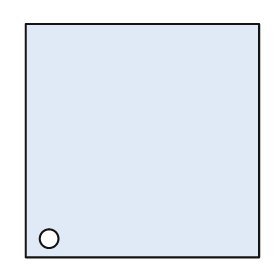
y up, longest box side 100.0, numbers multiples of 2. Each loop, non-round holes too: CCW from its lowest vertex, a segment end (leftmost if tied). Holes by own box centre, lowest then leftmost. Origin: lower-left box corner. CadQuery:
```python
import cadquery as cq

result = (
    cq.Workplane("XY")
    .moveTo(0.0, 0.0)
    .lineTo(100.0, 0.0)
    .lineTo(100.0, 100.0)
    .lineTo(0.0, 100.0)
    .close()
    .moveTo(10.0, 8.0)
    .circle(4.0)
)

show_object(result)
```